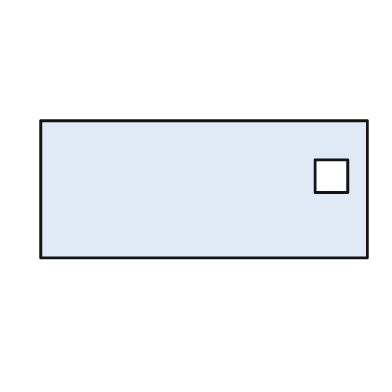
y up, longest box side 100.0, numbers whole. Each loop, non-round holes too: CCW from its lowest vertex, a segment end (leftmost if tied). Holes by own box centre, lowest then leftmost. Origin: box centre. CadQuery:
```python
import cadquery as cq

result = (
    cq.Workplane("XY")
    .moveTo(-50.0, -21.0)
    .lineTo(50.0, -21.0)
    .lineTo(50.0, 21.0)
    .lineTo(-50.0, 21.0)
    .close()
    .moveTo(34.0, -1.0)
    .lineTo(44.0, -1.0)
    .lineTo(44.0, 9.0)
    .lineTo(34.0, 9.0)
    .close()
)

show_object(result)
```